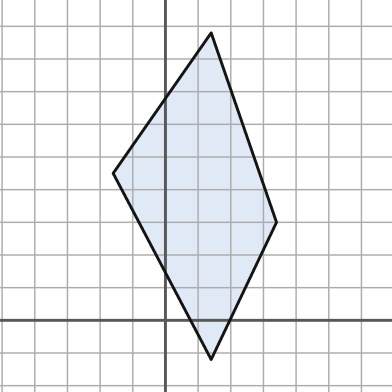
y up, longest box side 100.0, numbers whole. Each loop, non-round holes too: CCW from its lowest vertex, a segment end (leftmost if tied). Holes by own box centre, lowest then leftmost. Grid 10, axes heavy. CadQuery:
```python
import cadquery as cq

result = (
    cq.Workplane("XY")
    .moveTo(14.0, -12.0)
    .lineTo(34.0, 30.0)
    .lineTo(14.0, 88.0)
    .lineTo(-16.0, 45.0)
    .close()
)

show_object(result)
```